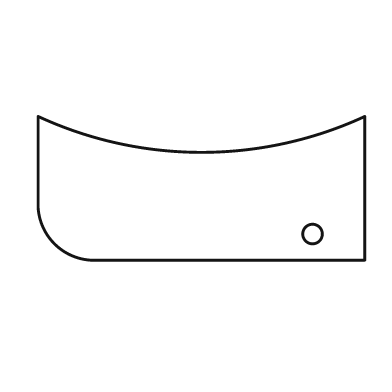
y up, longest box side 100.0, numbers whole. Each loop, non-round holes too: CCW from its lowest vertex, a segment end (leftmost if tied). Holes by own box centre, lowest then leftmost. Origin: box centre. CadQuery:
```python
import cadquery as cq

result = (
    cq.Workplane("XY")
    .moveTo(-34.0, -22.0)
    .lineTo(50.0, -22.0)
    .lineTo(50.0, 22.0)
    .threePointArc((0.0, 11.0), (-50.0, 22.0))
    .lineTo(-50.0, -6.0)
    .threePointArc((-45.0, -17.0), (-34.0, -22.0))
    .close()
    .moveTo(34.0, -14.0)
    .circle(3.0)
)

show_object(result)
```